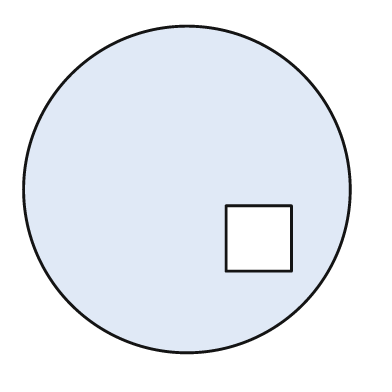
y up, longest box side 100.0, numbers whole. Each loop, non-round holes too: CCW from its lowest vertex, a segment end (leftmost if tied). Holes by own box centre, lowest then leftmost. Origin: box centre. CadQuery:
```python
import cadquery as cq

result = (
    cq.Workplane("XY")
    .moveTo(0.0, 0.0)
    .circle(50.0)
    .moveTo(12.0, -25.0)
    .lineTo(32.0, -25.0)
    .lineTo(32.0, -5.0)
    .lineTo(12.0, -5.0)
    .close()
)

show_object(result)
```